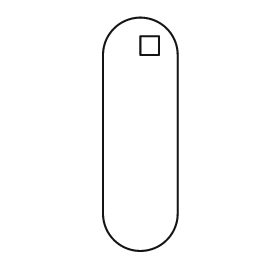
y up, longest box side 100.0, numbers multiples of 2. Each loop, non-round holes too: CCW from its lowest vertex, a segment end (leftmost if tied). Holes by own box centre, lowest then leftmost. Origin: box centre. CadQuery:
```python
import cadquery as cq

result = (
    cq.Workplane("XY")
    .moveTo(-16.0, -34.0)
    .threePointArc((0.0, -50.0), (16.0, -34.0))
    .lineTo(16.0, 34.0)
    .threePointArc((0.0, 50.0), (-16.0, 34.0))
    .close()
    .moveTo(0.0, 34.0)
    .lineTo(8.0, 34.0)
    .lineTo(8.0, 42.0)
    .lineTo(0.0, 42.0)
    .close()
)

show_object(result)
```